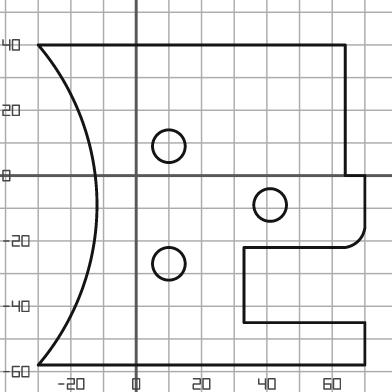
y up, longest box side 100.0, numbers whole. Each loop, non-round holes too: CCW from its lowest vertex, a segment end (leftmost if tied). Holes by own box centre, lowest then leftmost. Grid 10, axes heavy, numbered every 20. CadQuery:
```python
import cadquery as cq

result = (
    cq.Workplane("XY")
    .moveTo(-30.0, -58.0)
    .lineTo(70.0, -58.0)
    .lineTo(70.0, -45.0)
    .lineTo(33.0, -45.0)
    .lineTo(33.0, -22.0)
    .lineTo(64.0, -22.0)
    .threePointArc((68.0, -20.0), (70.0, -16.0))
    .lineTo(70.0, 0.0)
    .lineTo(64.0, 0.0)
    .lineTo(64.0, 40.0)
    .lineTo(-30.0, 40.0)
    .threePointArc((-12.0, -9.0), (-30.0, -58.0))
    .close()
    .moveTo(10.0, -27.0)
    .circle(5.0)
    .moveTo(41.0, -9.0)
    .circle(5.0)
    .moveTo(10.0, 9.0)
    .circle(5.0)
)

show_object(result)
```